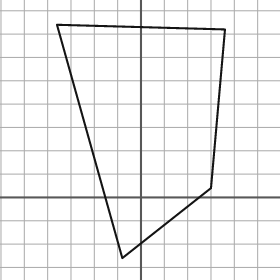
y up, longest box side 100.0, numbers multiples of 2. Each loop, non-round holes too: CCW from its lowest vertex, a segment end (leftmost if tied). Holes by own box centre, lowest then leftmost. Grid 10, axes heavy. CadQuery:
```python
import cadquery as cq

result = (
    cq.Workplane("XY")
    .moveTo(-8.0, -26.0)
    .lineTo(30.0, 4.0)
    .lineTo(36.0, 72.0)
    .lineTo(-36.0, 74.0)
    .close()
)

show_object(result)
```